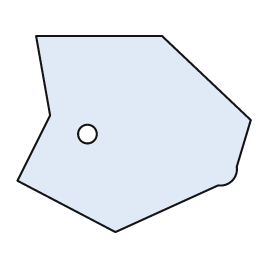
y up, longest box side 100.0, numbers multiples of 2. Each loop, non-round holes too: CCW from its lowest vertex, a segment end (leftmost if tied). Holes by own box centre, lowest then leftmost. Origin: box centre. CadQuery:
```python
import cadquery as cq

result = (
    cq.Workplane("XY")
    .moveTo(-8.0, -42.0)
    .lineTo(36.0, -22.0)
    .threePointArc((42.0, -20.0), (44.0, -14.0))
    .lineTo(50.0, 6.0)
    .lineTo(12.0, 42.0)
    .lineTo(-42.0, 42.0)
    .lineTo(-36.0, 8.0)
    .lineTo(-50.0, -20.0)
    .close()
    .moveTo(-20.0, 0.0)
    .circle(4.0)
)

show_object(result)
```